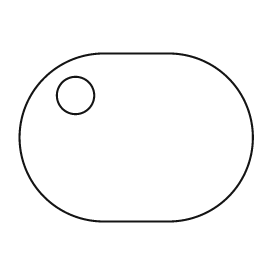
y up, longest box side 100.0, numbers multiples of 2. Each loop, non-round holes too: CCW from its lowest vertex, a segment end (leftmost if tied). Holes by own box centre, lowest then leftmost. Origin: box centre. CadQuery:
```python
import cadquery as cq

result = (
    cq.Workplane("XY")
    .moveTo(-14.0, -36.0)
    .lineTo(14.0, -36.0)
    .threePointArc((50.0, 0.0), (14.0, 36.0))
    .lineTo(-14.0, 36.0)
    .threePointArc((-50.0, 0.0), (-14.0, -36.0))
    .close()
    .moveTo(-26.0, 18.0)
    .circle(8.0)
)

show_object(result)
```